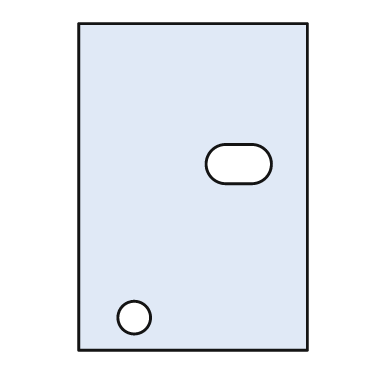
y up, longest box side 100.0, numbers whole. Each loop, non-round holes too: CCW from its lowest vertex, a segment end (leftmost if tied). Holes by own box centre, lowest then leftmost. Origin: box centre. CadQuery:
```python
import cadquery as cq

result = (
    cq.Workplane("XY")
    .moveTo(-35.0, -50.0)
    .lineTo(35.0, -50.0)
    .lineTo(35.0, 50.0)
    .lineTo(-35.0, 50.0)
    .close()
    .moveTo(-18.0, -40.0)
    .circle(5.0)
    .moveTo(10.0, 1.0)
    .lineTo(18.0, 1.0)
    .threePointArc((24.0, 7.0), (18.0, 13.0))
    .lineTo(10.0, 13.0)
    .threePointArc((4.0, 7.0), (10.0, 1.0))
    .close()
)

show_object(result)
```